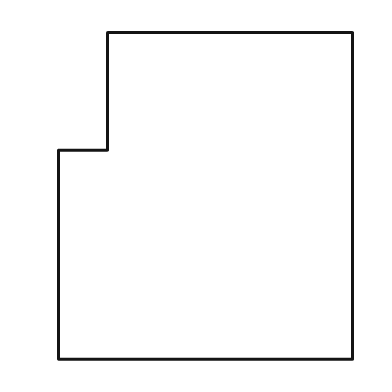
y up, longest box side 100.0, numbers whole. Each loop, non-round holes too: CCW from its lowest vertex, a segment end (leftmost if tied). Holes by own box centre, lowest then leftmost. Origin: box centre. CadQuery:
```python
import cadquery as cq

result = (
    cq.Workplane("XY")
    .moveTo(-45.0, -50.0)
    .lineTo(45.0, -50.0)
    .lineTo(45.0, 50.0)
    .lineTo(-30.0, 50.0)
    .lineTo(-30.0, 14.0)
    .lineTo(-45.0, 14.0)
    .close()
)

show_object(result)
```